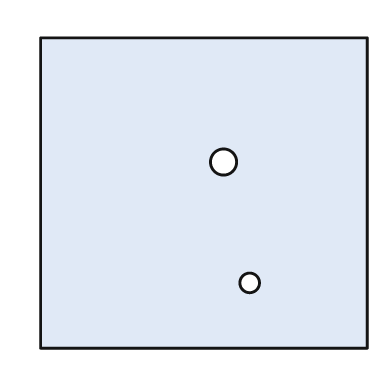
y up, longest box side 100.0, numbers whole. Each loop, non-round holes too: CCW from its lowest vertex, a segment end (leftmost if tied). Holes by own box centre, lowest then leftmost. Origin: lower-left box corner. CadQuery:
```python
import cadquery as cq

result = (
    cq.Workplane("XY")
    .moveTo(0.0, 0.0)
    .lineTo(100.0, 0.0)
    .lineTo(100.0, 95.0)
    .lineTo(0.0, 95.0)
    .close()
    .moveTo(64.0, 20.0)
    .circle(3.0)
    .moveTo(56.0, 57.0)
    .circle(4.0)
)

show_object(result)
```